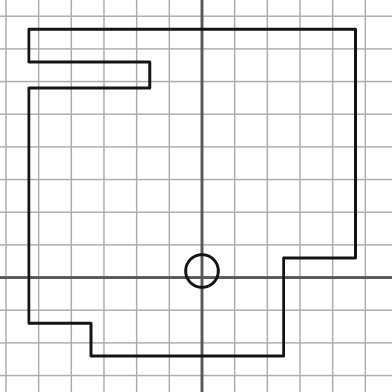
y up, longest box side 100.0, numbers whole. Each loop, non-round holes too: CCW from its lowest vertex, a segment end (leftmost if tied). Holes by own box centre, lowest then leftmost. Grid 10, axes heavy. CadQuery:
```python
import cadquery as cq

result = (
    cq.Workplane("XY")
    .moveTo(-34.0, -24.0)
    .lineTo(25.0, -24.0)
    .lineTo(25.0, 6.0)
    .lineTo(47.0, 6.0)
    .lineTo(47.0, 76.0)
    .lineTo(-53.0, 76.0)
    .lineTo(-53.0, 66.0)
    .lineTo(-16.0, 66.0)
    .lineTo(-16.0, 58.0)
    .lineTo(-53.0, 58.0)
    .lineTo(-53.0, -14.0)
    .lineTo(-34.0, -14.0)
    .close()
    .moveTo(0.0, 2.0)
    .circle(5.0)
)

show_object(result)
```